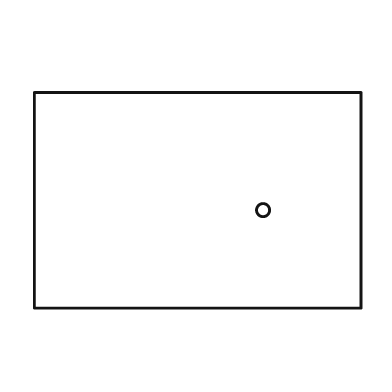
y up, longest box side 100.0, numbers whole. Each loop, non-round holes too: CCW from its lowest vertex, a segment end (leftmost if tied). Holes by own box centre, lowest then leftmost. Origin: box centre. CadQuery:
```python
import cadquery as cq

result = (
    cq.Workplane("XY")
    .moveTo(-50.0, -33.0)
    .lineTo(50.0, -33.0)
    .lineTo(50.0, 33.0)
    .lineTo(-50.0, 33.0)
    .close()
    .moveTo(20.0, -3.0)
    .circle(2.0)
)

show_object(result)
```